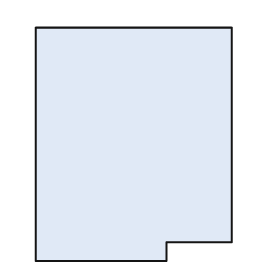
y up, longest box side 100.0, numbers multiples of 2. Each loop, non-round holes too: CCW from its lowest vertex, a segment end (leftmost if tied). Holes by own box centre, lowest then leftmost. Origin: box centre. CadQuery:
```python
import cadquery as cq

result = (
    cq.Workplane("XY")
    .moveTo(-42.0, -50.0)
    .lineTo(14.0, -50.0)
    .lineTo(14.0, -42.0)
    .lineTo(42.0, -42.0)
    .lineTo(42.0, 50.0)
    .lineTo(-42.0, 50.0)
    .close()
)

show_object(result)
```